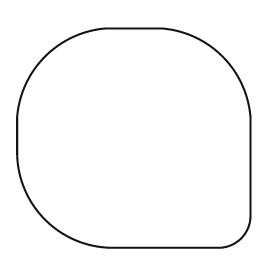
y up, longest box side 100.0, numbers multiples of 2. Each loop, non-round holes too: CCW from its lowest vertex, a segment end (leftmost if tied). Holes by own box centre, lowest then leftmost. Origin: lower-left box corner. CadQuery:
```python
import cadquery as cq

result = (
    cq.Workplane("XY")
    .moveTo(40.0, 0.0)
    .lineTo(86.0, 0.0)
    .threePointArc((96.0, 4.0), (100.0, 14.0))
    .lineTo(100.0, 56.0)
    .threePointArc((88.0, 82.0), (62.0, 94.0))
    .lineTo(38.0, 94.0)
    .threePointArc((12.0, 82.0), (0.0, 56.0))
    .lineTo(0.0, 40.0)
    .threePointArc((12.0, 12.0), (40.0, 0.0))
    .close()
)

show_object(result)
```